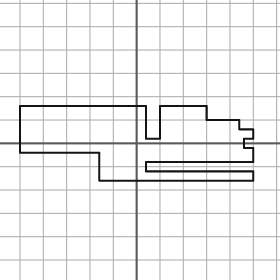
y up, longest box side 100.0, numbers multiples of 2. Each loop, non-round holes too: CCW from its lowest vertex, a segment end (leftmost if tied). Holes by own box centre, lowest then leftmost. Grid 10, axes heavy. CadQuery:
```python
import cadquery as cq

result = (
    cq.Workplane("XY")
    .moveTo(-16.0, -16.0)
    .lineTo(50.0, -16.0)
    .lineTo(50.0, -12.0)
    .lineTo(4.0, -12.0)
    .lineTo(4.0, -8.0)
    .lineTo(50.0, -8.0)
    .lineTo(50.0, -2.0)
    .lineTo(46.0, -2.0)
    .lineTo(46.0, 2.0)
    .lineTo(50.0, 2.0)
    .lineTo(50.0, 6.0)
    .lineTo(44.0, 6.0)
    .lineTo(44.0, 10.0)
    .lineTo(30.0, 10.0)
    .lineTo(30.0, 16.0)
    .lineTo(10.0, 16.0)
    .lineTo(10.0, 2.0)
    .lineTo(4.0, 2.0)
    .lineTo(4.0, 16.0)
    .lineTo(-50.0, 16.0)
    .lineTo(-50.0, -4.0)
    .lineTo(-16.0, -4.0)
    .close()
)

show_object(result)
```